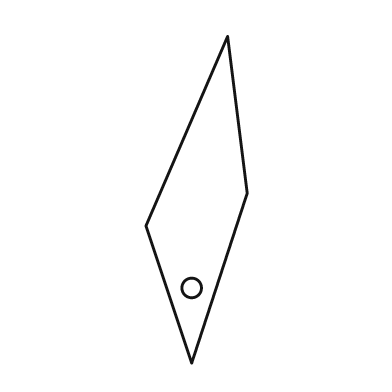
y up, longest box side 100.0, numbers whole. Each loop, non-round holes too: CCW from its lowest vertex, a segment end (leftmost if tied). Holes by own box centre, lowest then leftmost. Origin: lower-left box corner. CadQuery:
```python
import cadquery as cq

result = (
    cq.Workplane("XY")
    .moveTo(14.0, 0.0)
    .lineTo(31.0, 52.0)
    .lineTo(25.0, 100.0)
    .lineTo(0.0, 42.0)
    .close()
    .moveTo(14.0, 23.0)
    .circle(3.0)
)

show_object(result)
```